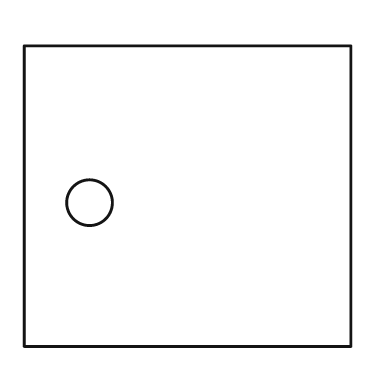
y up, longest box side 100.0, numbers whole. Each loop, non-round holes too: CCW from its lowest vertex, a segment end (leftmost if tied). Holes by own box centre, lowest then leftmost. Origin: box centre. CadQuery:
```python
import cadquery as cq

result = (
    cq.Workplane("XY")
    .moveTo(-50.0, -46.0)
    .lineTo(50.0, -46.0)
    .lineTo(50.0, 46.0)
    .lineTo(-50.0, 46.0)
    .close()
    .moveTo(-30.0, -2.0)
    .circle(7.0)
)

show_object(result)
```